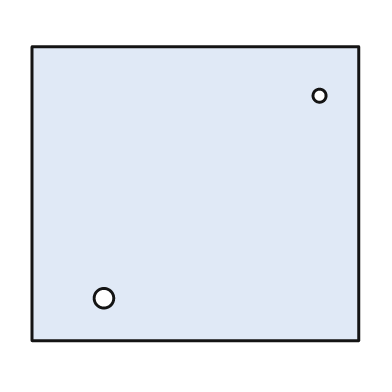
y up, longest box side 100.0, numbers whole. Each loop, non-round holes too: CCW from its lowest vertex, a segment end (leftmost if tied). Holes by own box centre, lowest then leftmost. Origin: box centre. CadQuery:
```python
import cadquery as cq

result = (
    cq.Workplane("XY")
    .moveTo(-50.0, -45.0)
    .lineTo(50.0, -45.0)
    .lineTo(50.0, 45.0)
    .lineTo(-50.0, 45.0)
    .close()
    .moveTo(-28.0, -32.0)
    .circle(3.0)
    .moveTo(38.0, 30.0)
    .circle(2.0)
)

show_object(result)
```